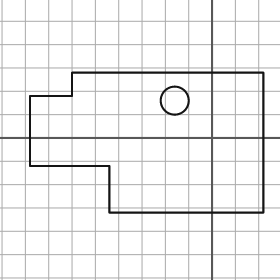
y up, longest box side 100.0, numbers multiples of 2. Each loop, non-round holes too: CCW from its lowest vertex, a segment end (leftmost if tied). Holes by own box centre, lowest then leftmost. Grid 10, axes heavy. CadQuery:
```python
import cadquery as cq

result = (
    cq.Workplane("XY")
    .moveTo(-44.0, -32.0)
    .lineTo(22.0, -32.0)
    .lineTo(22.0, 28.0)
    .lineTo(-60.0, 28.0)
    .lineTo(-60.0, 18.0)
    .lineTo(-78.0, 18.0)
    .lineTo(-78.0, -12.0)
    .lineTo(-44.0, -12.0)
    .close()
    .moveTo(-16.0, 16.0)
    .circle(6.0)
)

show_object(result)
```